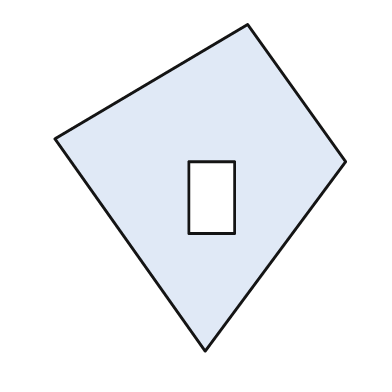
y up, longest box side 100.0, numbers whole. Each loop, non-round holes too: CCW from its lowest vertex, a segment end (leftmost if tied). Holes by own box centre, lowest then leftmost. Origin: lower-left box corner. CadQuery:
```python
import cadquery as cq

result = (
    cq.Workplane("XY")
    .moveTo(46.0, 0.0)
    .lineTo(89.0, 58.0)
    .lineTo(59.0, 100.0)
    .lineTo(0.0, 65.0)
    .close()
    .moveTo(41.0, 36.0)
    .lineTo(55.0, 36.0)
    .lineTo(55.0, 58.0)
    .lineTo(41.0, 58.0)
    .close()
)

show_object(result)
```